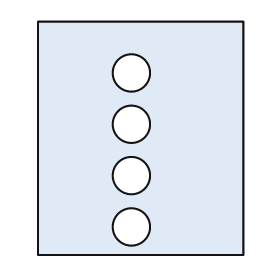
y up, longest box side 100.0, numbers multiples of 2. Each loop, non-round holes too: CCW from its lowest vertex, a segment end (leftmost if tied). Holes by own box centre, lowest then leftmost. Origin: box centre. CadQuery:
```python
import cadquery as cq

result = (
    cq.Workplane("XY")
    .moveTo(-44.0, -50.0)
    .lineTo(44.0, -50.0)
    .lineTo(44.0, 50.0)
    .lineTo(-44.0, 50.0)
    .close()
    .moveTo(-4.0, -38.0)
    .circle(8.0)
    .moveTo(-4.0, -16.0)
    .circle(8.0)
    .moveTo(-4.0, 6.0)
    .circle(8.0)
    .moveTo(-4.0, 28.0)
    .circle(8.0)
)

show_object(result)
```